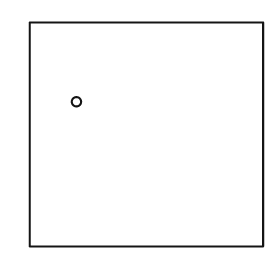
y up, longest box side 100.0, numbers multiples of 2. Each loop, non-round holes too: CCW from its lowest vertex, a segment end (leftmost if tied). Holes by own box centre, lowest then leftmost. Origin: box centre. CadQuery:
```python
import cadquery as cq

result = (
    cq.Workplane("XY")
    .moveTo(-50.0, -48.0)
    .lineTo(50.0, -48.0)
    .lineTo(50.0, 48.0)
    .lineTo(-50.0, 48.0)
    .close()
    .moveTo(-30.0, 14.0)
    .circle(2.0)
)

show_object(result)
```